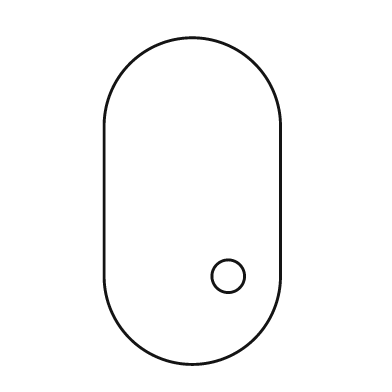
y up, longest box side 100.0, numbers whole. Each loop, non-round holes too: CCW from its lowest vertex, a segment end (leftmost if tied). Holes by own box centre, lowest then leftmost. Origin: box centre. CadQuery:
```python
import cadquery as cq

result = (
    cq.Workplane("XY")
    .moveTo(-27.0, -23.0)
    .threePointArc((0.0, -50.0), (27.0, -23.0))
    .lineTo(27.0, 23.0)
    .threePointArc((0.0, 50.0), (-27.0, 23.0))
    .close()
    .moveTo(11.0, -23.0)
    .circle(5.0)
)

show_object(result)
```